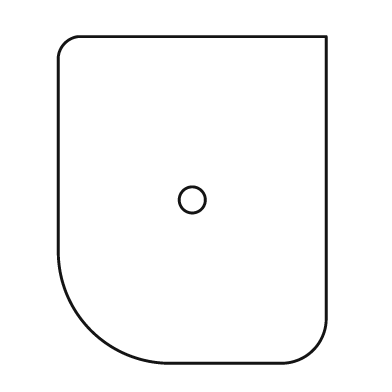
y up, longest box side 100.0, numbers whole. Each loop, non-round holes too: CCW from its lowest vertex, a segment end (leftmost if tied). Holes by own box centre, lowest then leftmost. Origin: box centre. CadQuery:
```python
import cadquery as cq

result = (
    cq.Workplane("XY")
    .moveTo(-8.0, -50.0)
    .lineTo(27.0, -50.0)
    .threePointArc((37.0, -46.0), (41.0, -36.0))
    .lineTo(41.0, 50.0)
    .lineTo(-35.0, 50.0)
    .threePointArc((-39.0, 48.0), (-41.0, 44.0))
    .lineTo(-41.0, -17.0)
    .threePointArc((-31.0, -40.0), (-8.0, -50.0))
    .close()
    .moveTo(0.0, 0.0)
    .circle(4.0)
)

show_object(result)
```